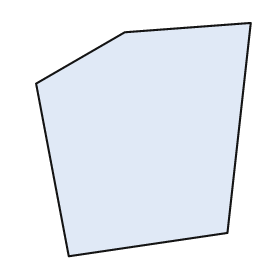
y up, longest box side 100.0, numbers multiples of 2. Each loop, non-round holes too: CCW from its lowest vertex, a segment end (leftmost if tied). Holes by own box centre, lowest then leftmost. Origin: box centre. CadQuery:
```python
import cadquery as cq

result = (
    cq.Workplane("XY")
    .moveTo(-32.0, -50.0)
    .lineTo(36.0, -40.0)
    .lineTo(46.0, 50.0)
    .lineTo(-8.0, 46.0)
    .lineTo(-46.0, 24.0)
    .close()
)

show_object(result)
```